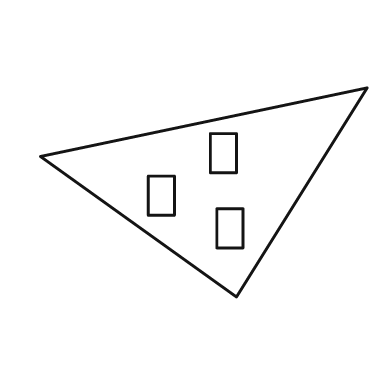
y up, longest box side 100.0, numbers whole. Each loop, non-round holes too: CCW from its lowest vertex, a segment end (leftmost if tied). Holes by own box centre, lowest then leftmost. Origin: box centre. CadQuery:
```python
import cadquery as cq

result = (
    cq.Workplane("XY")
    .moveTo(10.0, -32.0)
    .lineTo(50.0, 32.0)
    .lineTo(-50.0, 11.0)
    .close()
    .moveTo(4.0, -17.0)
    .lineTo(12.0, -17.0)
    .lineTo(12.0, -5.0)
    .lineTo(4.0, -5.0)
    .close()
    .moveTo(-17.0, -7.0)
    .lineTo(-9.0, -7.0)
    .lineTo(-9.0, 5.0)
    .lineTo(-17.0, 5.0)
    .close()
    .moveTo(2.0, 6.0)
    .lineTo(10.0, 6.0)
    .lineTo(10.0, 18.0)
    .lineTo(2.0, 18.0)
    .close()
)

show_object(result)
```